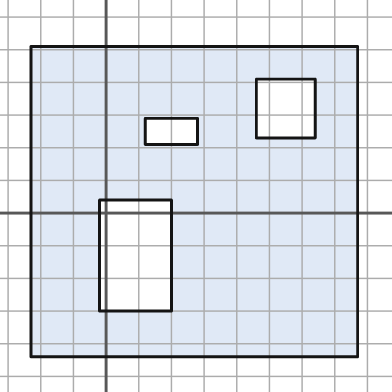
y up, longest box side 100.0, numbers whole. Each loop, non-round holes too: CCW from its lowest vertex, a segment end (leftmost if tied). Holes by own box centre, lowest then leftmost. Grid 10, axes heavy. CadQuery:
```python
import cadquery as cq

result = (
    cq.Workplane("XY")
    .moveTo(-23.0, -44.0)
    .lineTo(77.0, -44.0)
    .lineTo(77.0, 51.0)
    .lineTo(-23.0, 51.0)
    .close()
    .moveTo(-2.0, -30.0)
    .lineTo(20.0, -30.0)
    .lineTo(20.0, 4.0)
    .lineTo(-2.0, 4.0)
    .close()
    .moveTo(12.0, 21.0)
    .lineTo(28.0, 21.0)
    .lineTo(28.0, 29.0)
    .lineTo(12.0, 29.0)
    .close()
    .moveTo(46.0, 23.0)
    .lineTo(64.0, 23.0)
    .lineTo(64.0, 41.0)
    .lineTo(46.0, 41.0)
    .close()
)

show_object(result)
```